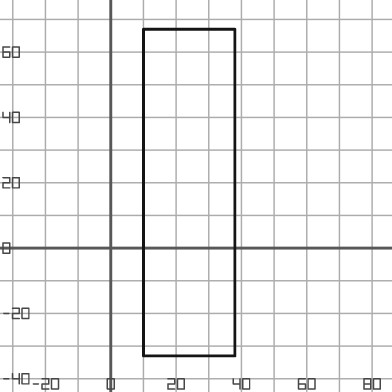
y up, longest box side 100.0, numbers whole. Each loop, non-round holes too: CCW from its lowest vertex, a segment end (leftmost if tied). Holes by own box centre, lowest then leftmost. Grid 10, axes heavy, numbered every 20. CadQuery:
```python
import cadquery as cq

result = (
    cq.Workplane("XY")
    .moveTo(10.0, -33.0)
    .lineTo(38.0, -33.0)
    .lineTo(38.0, 67.0)
    .lineTo(10.0, 67.0)
    .close()
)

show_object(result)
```